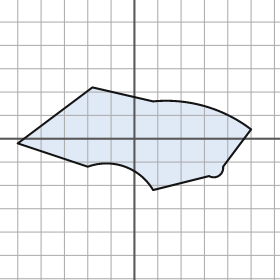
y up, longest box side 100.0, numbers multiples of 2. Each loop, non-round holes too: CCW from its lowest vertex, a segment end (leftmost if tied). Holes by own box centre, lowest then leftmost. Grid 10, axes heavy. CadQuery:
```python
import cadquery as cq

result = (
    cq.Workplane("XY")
    .moveTo(8.0, -22.0)
    .lineTo(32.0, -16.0)
    .threePointArc((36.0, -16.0), (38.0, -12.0))
    .lineTo(50.0, 4.0)
    .threePointArc((30.0, 14.0), (8.0, 16.0))
    .lineTo(-18.0, 22.0)
    .lineTo(-50.0, -2.0)
    .lineTo(-20.0, -12.0)
    .threePointArc((-4.0, -12.0), (8.0, -22.0))
    .close()
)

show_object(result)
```